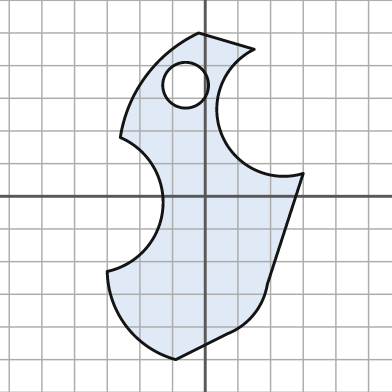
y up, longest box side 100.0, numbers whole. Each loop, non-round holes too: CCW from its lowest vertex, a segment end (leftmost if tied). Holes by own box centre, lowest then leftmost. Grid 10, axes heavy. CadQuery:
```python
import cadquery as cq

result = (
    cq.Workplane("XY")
    .moveTo(-9.0, -50.0)
    .lineTo(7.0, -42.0)
    .threePointArc((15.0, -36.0), (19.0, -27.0))
    .lineTo(30.0, 7.0)
    .threePointArc((5.0, 19.0), (15.0, 45.0))
    .lineTo(-2.0, 50.0)
    .threePointArc((-18.0, 37.0), (-26.0, 18.0))
    .threePointArc((-13.0, -4.0), (-30.0, -23.0))
    .threePointArc((-24.0, -40.0), (-9.0, -50.0))
    .close()
    .moveTo(-6.0, 34.0)
    .circle(7.0)
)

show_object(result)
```